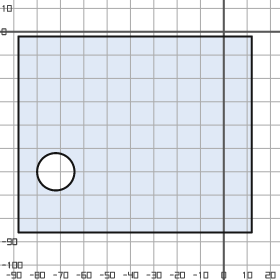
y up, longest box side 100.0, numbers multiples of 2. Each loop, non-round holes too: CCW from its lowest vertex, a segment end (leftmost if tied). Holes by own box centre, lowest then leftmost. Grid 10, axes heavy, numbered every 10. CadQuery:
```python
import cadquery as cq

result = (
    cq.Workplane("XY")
    .moveTo(-88.0, -86.0)
    .lineTo(12.0, -86.0)
    .lineTo(12.0, -2.0)
    .lineTo(-88.0, -2.0)
    .close()
    .moveTo(-72.0, -60.0)
    .circle(8.0)
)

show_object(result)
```